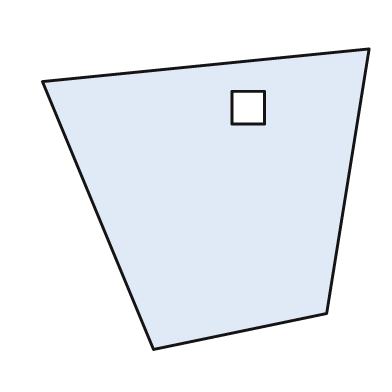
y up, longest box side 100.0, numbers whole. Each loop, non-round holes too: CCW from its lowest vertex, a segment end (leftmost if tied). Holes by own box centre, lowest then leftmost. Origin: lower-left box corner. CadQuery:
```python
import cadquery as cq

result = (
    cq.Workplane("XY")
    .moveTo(34.0, 0.0)
    .lineTo(87.0, 11.0)
    .lineTo(100.0, 92.0)
    .lineTo(0.0, 82.0)
    .close()
    .moveTo(58.0, 69.0)
    .lineTo(68.0, 69.0)
    .lineTo(68.0, 79.0)
    .lineTo(58.0, 79.0)
    .close()
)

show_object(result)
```